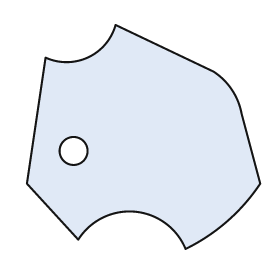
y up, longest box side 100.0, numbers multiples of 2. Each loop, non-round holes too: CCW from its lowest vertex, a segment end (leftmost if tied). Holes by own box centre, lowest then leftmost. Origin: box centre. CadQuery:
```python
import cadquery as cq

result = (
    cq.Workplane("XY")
    .moveTo(18.0, -48.0)
    .threePointArc((36.0, -36.0), (50.0, -20.0))
    .lineTo(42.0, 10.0)
    .threePointArc((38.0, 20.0), (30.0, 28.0))
    .lineTo(-12.0, 48.0)
    .threePointArc((-24.0, 34.0), (-42.0, 34.0))
    .lineTo(-50.0, -20.0)
    .lineTo(-28.0, -44.0)
    .threePointArc((-4.0, -32.0), (18.0, -48.0))
    .close()
    .moveTo(-30.0, -6.0)
    .circle(6.0)
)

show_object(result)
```